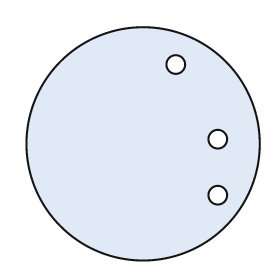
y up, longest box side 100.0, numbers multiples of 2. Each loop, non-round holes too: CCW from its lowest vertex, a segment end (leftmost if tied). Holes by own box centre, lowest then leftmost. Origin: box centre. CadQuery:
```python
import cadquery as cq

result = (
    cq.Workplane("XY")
    .moveTo(0.0, 0.0)
    .circle(50.0)
    .moveTo(32.0, -22.0)
    .circle(4.0)
    .moveTo(32.0, 2.0)
    .circle(4.0)
    .moveTo(14.0, 34.0)
    .circle(4.0)
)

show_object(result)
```